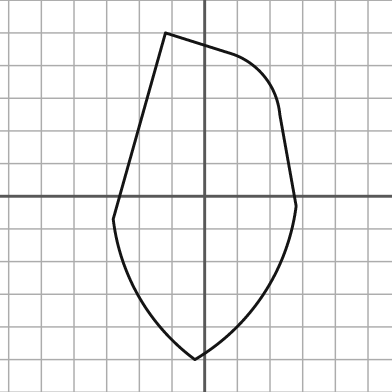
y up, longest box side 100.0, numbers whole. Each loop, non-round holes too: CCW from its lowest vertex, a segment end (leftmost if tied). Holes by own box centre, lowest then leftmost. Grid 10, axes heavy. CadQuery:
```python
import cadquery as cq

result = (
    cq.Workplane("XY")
    .moveTo(-3.0, -50.0)
    .threePointArc((18.0, -30.0), (28.0, -3.0))
    .lineTo(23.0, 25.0)
    .threePointArc((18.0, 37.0), (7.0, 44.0))
    .lineTo(-12.0, 50.0)
    .lineTo(-28.0, -7.0)
    .threePointArc((-20.0, -31.0), (-3.0, -50.0))
    .close()
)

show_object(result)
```